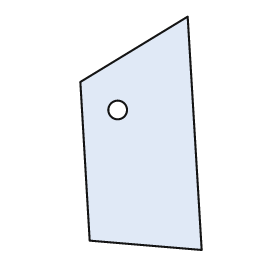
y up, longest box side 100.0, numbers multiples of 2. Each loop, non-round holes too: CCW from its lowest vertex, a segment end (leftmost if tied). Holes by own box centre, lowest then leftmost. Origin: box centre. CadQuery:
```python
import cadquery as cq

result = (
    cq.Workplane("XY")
    .moveTo(26.0, -50.0)
    .lineTo(20.0, 50.0)
    .lineTo(-26.0, 22.0)
    .lineTo(-22.0, -46.0)
    .close()
    .moveTo(-10.0, 10.0)
    .circle(4.0)
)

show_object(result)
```